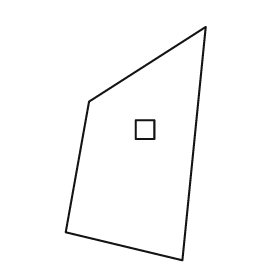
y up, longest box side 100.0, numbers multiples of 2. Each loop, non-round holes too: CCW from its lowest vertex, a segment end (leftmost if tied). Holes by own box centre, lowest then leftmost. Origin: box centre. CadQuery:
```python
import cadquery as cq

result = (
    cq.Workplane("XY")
    .moveTo(20.0, -50.0)
    .lineTo(30.0, 50.0)
    .lineTo(-20.0, 18.0)
    .lineTo(-30.0, -38.0)
    .close()
    .moveTo(0.0, 2.0)
    .lineTo(8.0, 2.0)
    .lineTo(8.0, 10.0)
    .lineTo(0.0, 10.0)
    .close()
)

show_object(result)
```